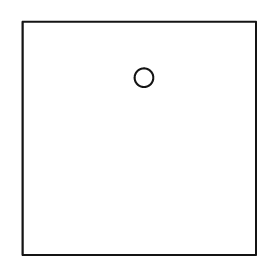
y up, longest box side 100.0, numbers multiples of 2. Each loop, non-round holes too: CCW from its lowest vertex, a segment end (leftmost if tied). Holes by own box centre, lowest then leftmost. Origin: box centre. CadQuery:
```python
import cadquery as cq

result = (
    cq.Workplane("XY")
    .moveTo(-50.0, -50.0)
    .lineTo(50.0, -50.0)
    .lineTo(50.0, 50.0)
    .lineTo(-50.0, 50.0)
    .close()
    .moveTo(2.0, 26.0)
    .circle(4.0)
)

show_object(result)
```